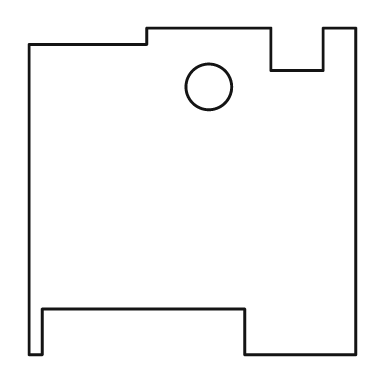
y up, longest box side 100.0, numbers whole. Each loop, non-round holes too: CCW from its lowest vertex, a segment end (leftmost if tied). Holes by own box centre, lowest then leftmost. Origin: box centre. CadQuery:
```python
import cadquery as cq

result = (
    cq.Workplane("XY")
    .moveTo(-50.0, -50.0)
    .lineTo(-46.0, -50.0)
    .lineTo(-46.0, -36.0)
    .lineTo(16.0, -36.0)
    .lineTo(16.0, -50.0)
    .lineTo(50.0, -50.0)
    .lineTo(50.0, 50.0)
    .lineTo(40.0, 50.0)
    .lineTo(40.0, 37.0)
    .lineTo(24.0, 37.0)
    .lineTo(24.0, 50.0)
    .lineTo(-14.0, 50.0)
    .lineTo(-14.0, 45.0)
    .lineTo(-50.0, 45.0)
    .close()
    .moveTo(5.0, 32.0)
    .circle(7.0)
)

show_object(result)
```